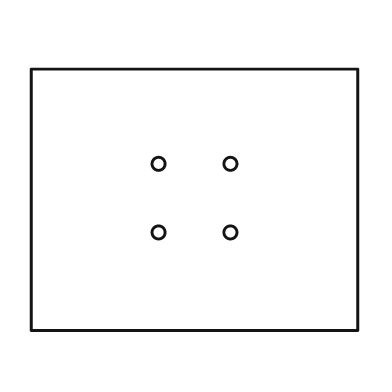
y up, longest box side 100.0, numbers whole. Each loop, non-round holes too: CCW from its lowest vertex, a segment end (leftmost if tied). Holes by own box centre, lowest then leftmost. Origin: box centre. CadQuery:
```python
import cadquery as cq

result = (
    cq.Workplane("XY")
    .moveTo(-50.0, -40.0)
    .lineTo(50.0, -40.0)
    .lineTo(50.0, 40.0)
    .lineTo(-50.0, 40.0)
    .close()
    .moveTo(-11.0, -10.0)
    .circle(2.0)
    .moveTo(11.0, -10.0)
    .circle(2.0)
    .moveTo(-11.0, 11.0)
    .circle(2.0)
    .moveTo(11.0, 11.0)
    .circle(2.0)
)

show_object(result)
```